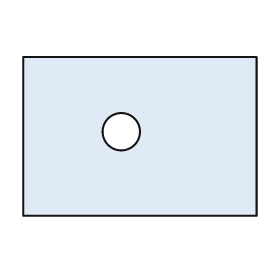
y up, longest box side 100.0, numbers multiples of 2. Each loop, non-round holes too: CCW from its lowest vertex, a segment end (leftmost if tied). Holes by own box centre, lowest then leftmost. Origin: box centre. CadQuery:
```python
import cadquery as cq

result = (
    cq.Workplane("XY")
    .moveTo(-50.0, -34.0)
    .lineTo(50.0, -34.0)
    .lineTo(50.0, 34.0)
    .lineTo(-50.0, 34.0)
    .close()
    .moveTo(-8.0, 2.0)
    .circle(8.0)
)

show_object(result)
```